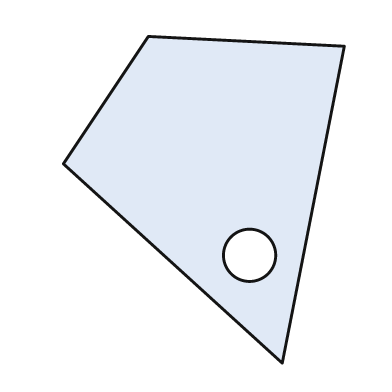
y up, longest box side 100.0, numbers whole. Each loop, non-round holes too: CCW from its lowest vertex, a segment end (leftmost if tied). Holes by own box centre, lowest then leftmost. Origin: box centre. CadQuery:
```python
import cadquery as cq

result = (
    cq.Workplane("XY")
    .moveTo(24.0, -50.0)
    .lineTo(43.0, 47.0)
    .lineTo(-17.0, 50.0)
    .lineTo(-43.0, 11.0)
    .close()
    .moveTo(14.0, -17.0)
    .circle(8.0)
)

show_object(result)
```